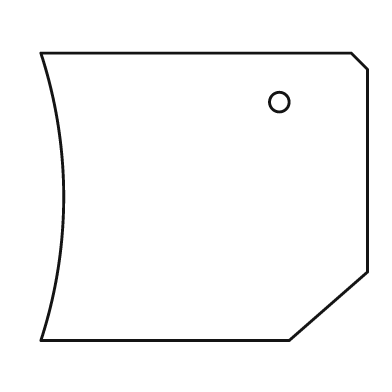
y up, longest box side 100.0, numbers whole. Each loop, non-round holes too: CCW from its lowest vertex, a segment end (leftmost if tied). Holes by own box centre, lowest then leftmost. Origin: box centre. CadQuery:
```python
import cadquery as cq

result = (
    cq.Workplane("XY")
    .moveTo(-50.0, -44.0)
    .lineTo(26.0, -44.0)
    .lineTo(50.0, -23.0)
    .lineTo(50.0, 39.0)
    .lineTo(45.0, 44.0)
    .lineTo(-50.0, 44.0)
    .threePointArc((-43.0, 0.0), (-50.0, -44.0))
    .close()
    .moveTo(23.0, 29.0)
    .circle(3.0)
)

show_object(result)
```